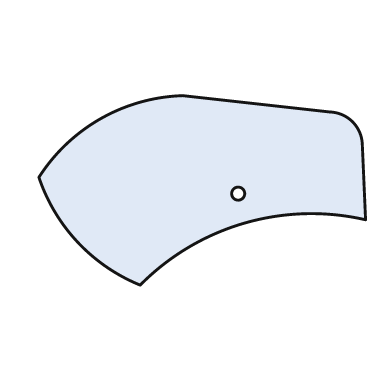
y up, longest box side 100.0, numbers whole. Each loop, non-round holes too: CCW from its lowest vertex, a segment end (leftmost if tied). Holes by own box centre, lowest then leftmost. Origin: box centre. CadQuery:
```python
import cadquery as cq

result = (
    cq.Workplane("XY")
    .moveTo(-19.0, -29.0)
    .threePointArc((13.0, -10.0), (50.0, -9.0))
    .lineTo(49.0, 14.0)
    .threePointArc((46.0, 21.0), (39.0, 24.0))
    .lineTo(-6.0, 29.0)
    .threePointArc((-31.0, 22.0), (-50.0, 4.0))
    .threePointArc((-38.0, -16.0), (-19.0, -29.0))
    .close()
    .moveTo(11.0, -1.0)
    .circle(2.0)
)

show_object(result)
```